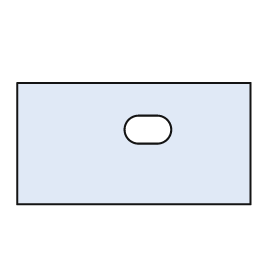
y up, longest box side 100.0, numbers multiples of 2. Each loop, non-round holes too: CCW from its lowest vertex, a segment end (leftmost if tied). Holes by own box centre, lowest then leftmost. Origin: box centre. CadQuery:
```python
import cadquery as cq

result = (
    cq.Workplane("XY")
    .moveTo(-50.0, -26.0)
    .lineTo(50.0, -26.0)
    .lineTo(50.0, 26.0)
    .lineTo(-50.0, 26.0)
    .close()
    .moveTo(2.0, 0.0)
    .lineTo(10.0, 0.0)
    .threePointArc((16.0, 6.0), (10.0, 12.0))
    .lineTo(2.0, 12.0)
    .threePointArc((-4.0, 6.0), (2.0, 0.0))
    .close()
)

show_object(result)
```